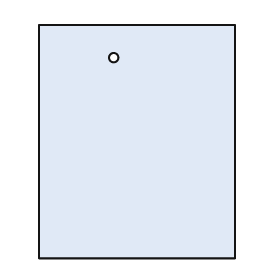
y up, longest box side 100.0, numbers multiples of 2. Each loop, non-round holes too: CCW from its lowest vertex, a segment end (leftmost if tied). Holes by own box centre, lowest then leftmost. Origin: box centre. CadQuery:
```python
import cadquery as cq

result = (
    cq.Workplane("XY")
    .moveTo(-42.0, -50.0)
    .lineTo(42.0, -50.0)
    .lineTo(42.0, 50.0)
    .lineTo(-42.0, 50.0)
    .close()
    .moveTo(-10.0, 36.0)
    .circle(2.0)
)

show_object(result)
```